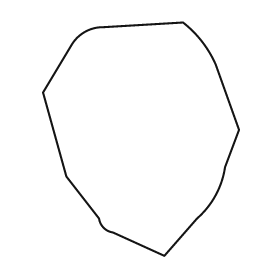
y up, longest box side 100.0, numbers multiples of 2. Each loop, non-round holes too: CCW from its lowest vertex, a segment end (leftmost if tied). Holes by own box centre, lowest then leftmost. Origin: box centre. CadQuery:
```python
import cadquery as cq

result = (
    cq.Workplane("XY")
    .moveTo(10.0, -50.0)
    .lineTo(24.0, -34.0)
    .threePointArc((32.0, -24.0), (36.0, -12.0))
    .lineTo(42.0, 4.0)
    .lineTo(32.0, 32.0)
    .threePointArc((26.0, 42.0), (18.0, 50.0))
    .lineTo(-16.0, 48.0)
    .threePointArc((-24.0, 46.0), (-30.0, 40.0))
    .lineTo(-42.0, 20.0)
    .lineTo(-32.0, -16.0)
    .lineTo(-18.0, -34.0)
    .threePointArc((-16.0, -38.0), (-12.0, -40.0))
    .close()
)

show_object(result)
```